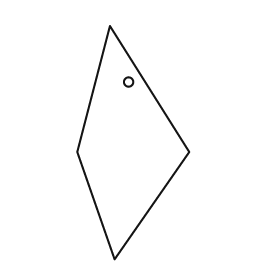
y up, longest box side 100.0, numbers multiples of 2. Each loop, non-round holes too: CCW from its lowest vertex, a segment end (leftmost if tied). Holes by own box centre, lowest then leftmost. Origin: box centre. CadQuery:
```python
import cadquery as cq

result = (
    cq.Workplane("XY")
    .moveTo(-8.0, -50.0)
    .lineTo(24.0, -4.0)
    .lineTo(-10.0, 50.0)
    .lineTo(-24.0, -4.0)
    .close()
    .moveTo(-2.0, 26.0)
    .circle(2.0)
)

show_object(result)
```